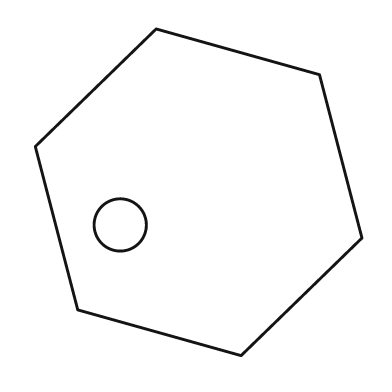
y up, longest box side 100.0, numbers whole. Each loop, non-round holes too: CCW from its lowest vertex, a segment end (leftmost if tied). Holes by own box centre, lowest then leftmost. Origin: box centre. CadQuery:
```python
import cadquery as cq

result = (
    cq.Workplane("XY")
    .moveTo(13.0, -50.0)
    .lineTo(50.0, -14.0)
    .lineTo(37.0, 36.0)
    .lineTo(-13.0, 50.0)
    .lineTo(-50.0, 14.0)
    .lineTo(-37.0, -36.0)
    .close()
    .moveTo(-24.0, -10.0)
    .circle(8.0)
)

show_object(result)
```